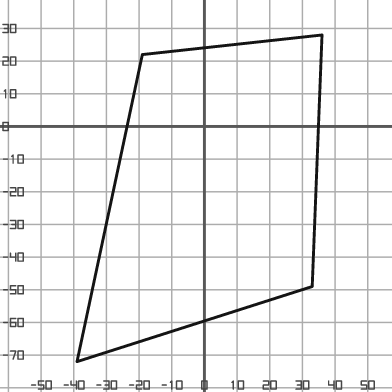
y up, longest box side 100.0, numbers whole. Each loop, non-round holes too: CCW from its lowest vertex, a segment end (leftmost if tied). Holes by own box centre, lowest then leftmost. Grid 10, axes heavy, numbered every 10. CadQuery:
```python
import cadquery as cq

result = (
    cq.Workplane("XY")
    .moveTo(-39.0, -72.0)
    .lineTo(33.0, -49.0)
    .lineTo(36.0, 28.0)
    .lineTo(-19.0, 22.0)
    .close()
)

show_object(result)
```